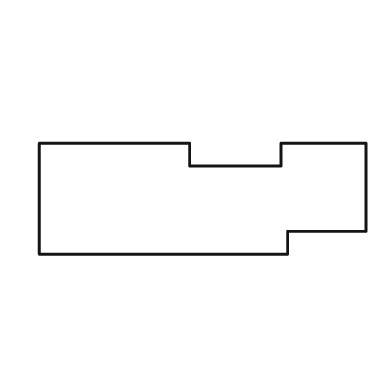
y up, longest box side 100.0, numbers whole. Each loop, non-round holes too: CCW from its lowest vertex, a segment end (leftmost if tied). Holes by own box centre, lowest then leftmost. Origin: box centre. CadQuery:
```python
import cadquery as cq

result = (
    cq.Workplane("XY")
    .moveTo(-50.0, -17.0)
    .lineTo(26.0, -17.0)
    .lineTo(26.0, -10.0)
    .lineTo(50.0, -10.0)
    .lineTo(50.0, 17.0)
    .lineTo(24.0, 17.0)
    .lineTo(24.0, 10.0)
    .lineTo(-4.0, 10.0)
    .lineTo(-4.0, 17.0)
    .lineTo(-50.0, 17.0)
    .close()
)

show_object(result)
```